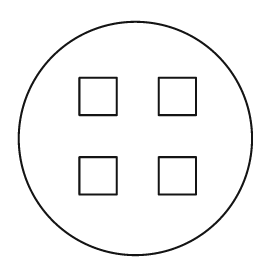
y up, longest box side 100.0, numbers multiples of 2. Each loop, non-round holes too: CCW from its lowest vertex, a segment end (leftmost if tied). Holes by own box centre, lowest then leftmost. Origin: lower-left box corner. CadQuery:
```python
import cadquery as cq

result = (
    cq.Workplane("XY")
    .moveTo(50.0, 50.0)
    .circle(50.0)
    .moveTo(26.0, 26.0)
    .lineTo(42.0, 26.0)
    .lineTo(42.0, 42.0)
    .lineTo(26.0, 42.0)
    .close()
    .moveTo(60.0, 26.0)
    .lineTo(76.0, 26.0)
    .lineTo(76.0, 42.0)
    .lineTo(60.0, 42.0)
    .close()
    .moveTo(26.0, 60.0)
    .lineTo(42.0, 60.0)
    .lineTo(42.0, 76.0)
    .lineTo(26.0, 76.0)
    .close()
    .moveTo(60.0, 60.0)
    .lineTo(76.0, 60.0)
    .lineTo(76.0, 76.0)
    .lineTo(60.0, 76.0)
    .close()
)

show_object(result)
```